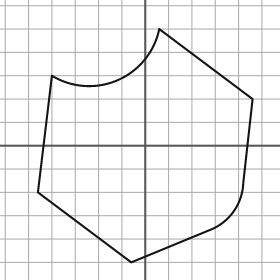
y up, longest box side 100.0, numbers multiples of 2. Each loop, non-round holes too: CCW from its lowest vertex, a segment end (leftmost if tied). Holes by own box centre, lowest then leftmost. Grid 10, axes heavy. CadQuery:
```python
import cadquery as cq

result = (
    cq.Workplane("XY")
    .moveTo(-6.0, -50.0)
    .lineTo(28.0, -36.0)
    .threePointArc((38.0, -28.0), (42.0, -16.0))
    .lineTo(46.0, 20.0)
    .lineTo(6.0, 50.0)
    .threePointArc((-12.0, 28.0), (-40.0, 30.0))
    .lineTo(-46.0, -20.0)
    .close()
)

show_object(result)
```